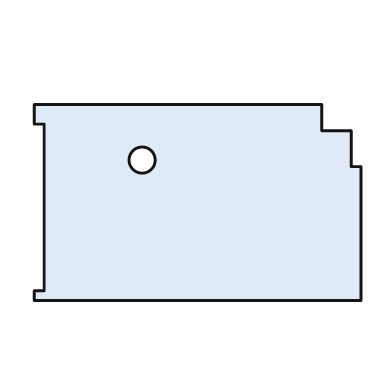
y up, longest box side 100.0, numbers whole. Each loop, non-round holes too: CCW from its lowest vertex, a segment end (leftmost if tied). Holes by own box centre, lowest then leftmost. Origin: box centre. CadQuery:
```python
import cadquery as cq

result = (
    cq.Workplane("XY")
    .moveTo(-50.0, -30.0)
    .lineTo(50.0, -30.0)
    .lineTo(50.0, 11.0)
    .lineTo(47.0, 11.0)
    .lineTo(47.0, 22.0)
    .lineTo(38.0, 22.0)
    .lineTo(38.0, 30.0)
    .lineTo(-50.0, 30.0)
    .lineTo(-50.0, 24.0)
    .lineTo(-47.0, 24.0)
    .lineTo(-47.0, -27.0)
    .lineTo(-50.0, -27.0)
    .close()
    .moveTo(-17.0, 13.0)
    .circle(4.0)
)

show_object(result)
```